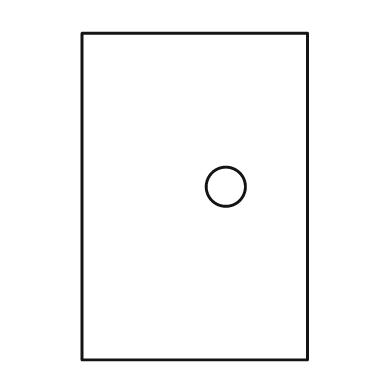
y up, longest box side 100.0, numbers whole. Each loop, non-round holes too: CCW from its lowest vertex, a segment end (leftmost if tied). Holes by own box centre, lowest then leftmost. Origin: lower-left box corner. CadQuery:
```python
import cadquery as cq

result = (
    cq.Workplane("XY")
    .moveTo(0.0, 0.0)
    .lineTo(69.0, 0.0)
    .lineTo(69.0, 100.0)
    .lineTo(0.0, 100.0)
    .close()
    .moveTo(44.0, 53.0)
    .circle(6.0)
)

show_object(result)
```